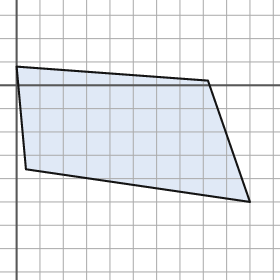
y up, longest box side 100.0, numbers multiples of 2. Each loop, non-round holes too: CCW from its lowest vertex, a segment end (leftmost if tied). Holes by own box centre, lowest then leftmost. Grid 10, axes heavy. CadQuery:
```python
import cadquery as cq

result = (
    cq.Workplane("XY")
    .moveTo(100.0, -50.0)
    .lineTo(82.0, 2.0)
    .lineTo(0.0, 8.0)
    .lineTo(4.0, -36.0)
    .close()
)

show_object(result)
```